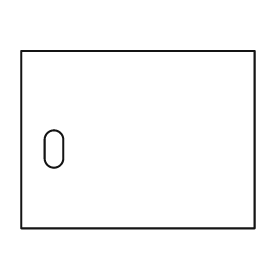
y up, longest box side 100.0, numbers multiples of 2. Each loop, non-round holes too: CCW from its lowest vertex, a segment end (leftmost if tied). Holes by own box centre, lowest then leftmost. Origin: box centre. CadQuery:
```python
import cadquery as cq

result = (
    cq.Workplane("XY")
    .moveTo(-50.0, -38.0)
    .lineTo(50.0, -38.0)
    .lineTo(50.0, 38.0)
    .lineTo(-50.0, 38.0)
    .close()
    .moveTo(-40.0, -8.0)
    .threePointArc((-36.0, -12.0), (-32.0, -8.0))
    .lineTo(-32.0, 0.0)
    .threePointArc((-36.0, 4.0), (-40.0, 0.0))
    .close()
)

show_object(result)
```